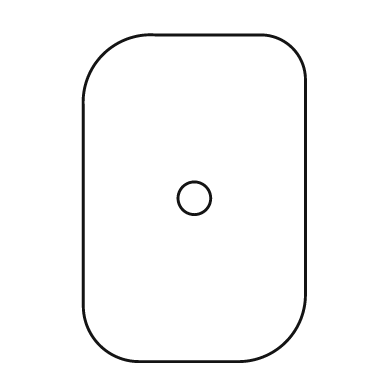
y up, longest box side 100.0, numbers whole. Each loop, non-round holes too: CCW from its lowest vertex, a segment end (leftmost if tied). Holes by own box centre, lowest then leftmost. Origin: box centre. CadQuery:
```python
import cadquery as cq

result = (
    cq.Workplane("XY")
    .moveTo(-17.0, -50.0)
    .lineTo(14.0, -50.0)
    .threePointArc((28.0, -44.0), (34.0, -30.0))
    .lineTo(34.0, 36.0)
    .threePointArc((30.0, 46.0), (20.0, 50.0))
    .lineTo(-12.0, 50.0)
    .threePointArc((-28.0, 44.0), (-34.0, 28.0))
    .lineTo(-34.0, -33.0)
    .threePointArc((-29.0, -45.0), (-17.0, -50.0))
    .close()
    .moveTo(0.0, 0.0)
    .circle(5.0)
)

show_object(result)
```